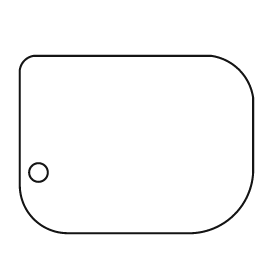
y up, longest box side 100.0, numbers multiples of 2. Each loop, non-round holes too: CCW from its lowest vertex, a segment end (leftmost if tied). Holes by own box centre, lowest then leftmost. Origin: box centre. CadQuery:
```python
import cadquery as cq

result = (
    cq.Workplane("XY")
    .moveTo(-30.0, -38.0)
    .lineTo(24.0, -38.0)
    .threePointArc((42.0, -30.0), (50.0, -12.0))
    .lineTo(50.0, 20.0)
    .threePointArc((44.0, 32.0), (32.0, 38.0))
    .lineTo(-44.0, 38.0)
    .threePointArc((-48.0, 36.0), (-50.0, 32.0))
    .lineTo(-50.0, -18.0)
    .threePointArc((-44.0, -32.0), (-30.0, -38.0))
    .close()
    .moveTo(-42.0, -12.0)
    .circle(4.0)
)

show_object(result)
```